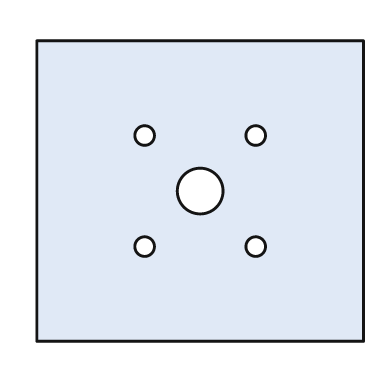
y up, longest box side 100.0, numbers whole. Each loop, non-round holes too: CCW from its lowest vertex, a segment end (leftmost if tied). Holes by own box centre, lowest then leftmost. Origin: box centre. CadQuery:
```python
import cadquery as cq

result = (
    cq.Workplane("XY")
    .moveTo(-50.0, -46.0)
    .lineTo(50.0, -46.0)
    .lineTo(50.0, 46.0)
    .lineTo(-50.0, 46.0)
    .close()
    .moveTo(-17.0, -17.0)
    .circle(3.0)
    .moveTo(17.0, -17.0)
    .circle(3.0)
    .moveTo(0.0, 0.0)
    .circle(7.0)
    .moveTo(-17.0, 17.0)
    .circle(3.0)
    .moveTo(17.0, 17.0)
    .circle(3.0)
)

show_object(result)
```